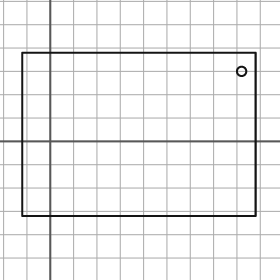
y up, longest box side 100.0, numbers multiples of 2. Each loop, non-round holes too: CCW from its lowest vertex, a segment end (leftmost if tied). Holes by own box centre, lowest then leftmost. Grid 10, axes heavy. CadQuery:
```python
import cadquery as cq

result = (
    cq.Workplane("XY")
    .moveTo(-12.0, -32.0)
    .lineTo(88.0, -32.0)
    .lineTo(88.0, 38.0)
    .lineTo(-12.0, 38.0)
    .close()
    .moveTo(82.0, 30.0)
    .circle(2.0)
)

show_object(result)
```